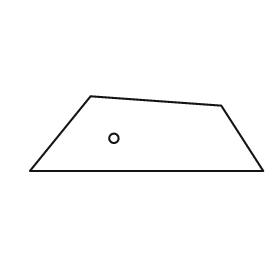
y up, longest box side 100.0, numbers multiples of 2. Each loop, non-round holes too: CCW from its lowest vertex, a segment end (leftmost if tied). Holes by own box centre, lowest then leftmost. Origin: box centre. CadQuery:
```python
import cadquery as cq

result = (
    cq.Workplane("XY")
    .moveTo(-50.0, -16.0)
    .lineTo(50.0, -16.0)
    .lineTo(32.0, 12.0)
    .lineTo(-24.0, 16.0)
    .close()
    .moveTo(-14.0, -2.0)
    .circle(2.0)
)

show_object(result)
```